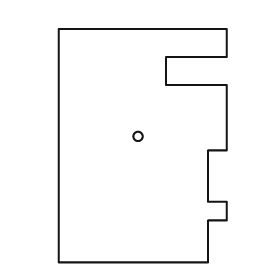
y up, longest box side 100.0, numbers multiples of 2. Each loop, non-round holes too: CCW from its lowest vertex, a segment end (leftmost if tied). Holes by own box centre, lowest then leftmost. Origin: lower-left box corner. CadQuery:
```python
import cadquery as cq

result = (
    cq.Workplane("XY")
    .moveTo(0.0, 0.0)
    .lineTo(64.0, 0.0)
    .lineTo(64.0, 18.0)
    .lineTo(72.0, 18.0)
    .lineTo(72.0, 26.0)
    .lineTo(64.0, 26.0)
    .lineTo(64.0, 48.0)
    .lineTo(72.0, 48.0)
    .lineTo(72.0, 76.0)
    .lineTo(46.0, 76.0)
    .lineTo(46.0, 88.0)
    .lineTo(72.0, 88.0)
    .lineTo(72.0, 100.0)
    .lineTo(0.0, 100.0)
    .close()
    .moveTo(34.0, 54.0)
    .circle(2.0)
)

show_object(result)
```